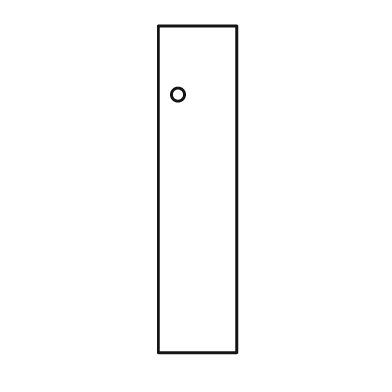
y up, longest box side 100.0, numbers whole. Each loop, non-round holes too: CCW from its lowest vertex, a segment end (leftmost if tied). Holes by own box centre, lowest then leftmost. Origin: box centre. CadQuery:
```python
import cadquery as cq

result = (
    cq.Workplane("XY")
    .moveTo(-12.0, -50.0)
    .lineTo(12.0, -50.0)
    .lineTo(12.0, 50.0)
    .lineTo(-12.0, 50.0)
    .close()
    .moveTo(-6.0, 29.0)
    .circle(2.0)
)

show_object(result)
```